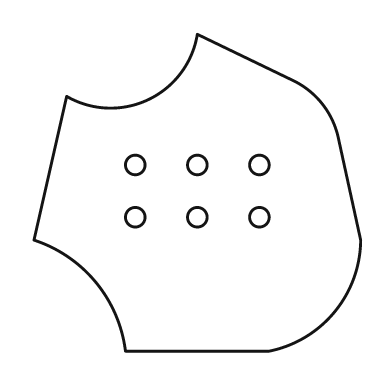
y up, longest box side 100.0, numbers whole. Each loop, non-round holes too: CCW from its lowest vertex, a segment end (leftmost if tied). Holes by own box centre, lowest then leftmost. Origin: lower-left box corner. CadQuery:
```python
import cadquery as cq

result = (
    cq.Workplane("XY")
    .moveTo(28.0, 0.0)
    .lineTo(72.0, 0.0)
    .threePointArc((92.0, 12.0), (100.0, 34.0))
    .lineTo(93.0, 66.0)
    .threePointArc((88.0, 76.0), (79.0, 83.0))
    .lineTo(50.0, 97.0)
    .threePointArc((35.0, 77.0), (10.0, 78.0))
    .lineTo(0.0, 34.0)
    .threePointArc((19.0, 21.0), (28.0, 0.0))
    .close()
    .moveTo(31.0, 41.0)
    .circle(3.0)
    .moveTo(50.0, 41.0)
    .circle(3.0)
    .moveTo(69.0, 41.0)
    .circle(3.0)
    .moveTo(31.0, 57.0)
    .circle(3.0)
    .moveTo(50.0, 57.0)
    .circle(3.0)
    .moveTo(69.0, 57.0)
    .circle(3.0)
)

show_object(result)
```